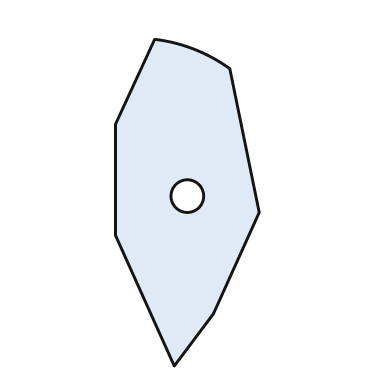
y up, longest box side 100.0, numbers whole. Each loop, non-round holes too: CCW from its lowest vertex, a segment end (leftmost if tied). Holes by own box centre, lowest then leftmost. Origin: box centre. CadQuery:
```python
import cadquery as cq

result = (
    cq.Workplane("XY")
    .moveTo(-4.0, -50.0)
    .lineTo(8.0, -34.0)
    .lineTo(22.0, -3.0)
    .lineTo(13.0, 41.0)
    .threePointArc((2.0, 47.0), (-10.0, 50.0))
    .lineTo(-22.0, 24.0)
    .lineTo(-22.0, -10.0)
    .close()
    .moveTo(0.0, 2.0)
    .circle(5.0)
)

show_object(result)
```